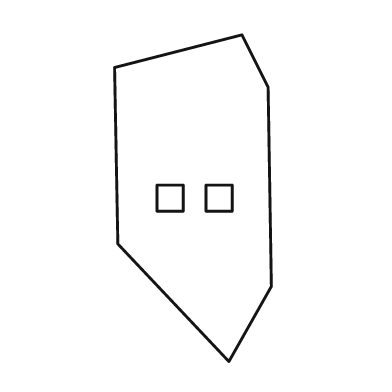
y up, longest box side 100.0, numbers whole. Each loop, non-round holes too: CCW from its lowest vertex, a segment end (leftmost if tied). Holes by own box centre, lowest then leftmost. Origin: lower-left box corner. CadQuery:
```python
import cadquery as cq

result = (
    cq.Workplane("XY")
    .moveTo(35.0, 0.0)
    .lineTo(48.0, 23.0)
    .lineTo(47.0, 84.0)
    .lineTo(39.0, 100.0)
    .lineTo(0.0, 90.0)
    .lineTo(1.0, 36.0)
    .close()
    .moveTo(13.0, 46.0)
    .lineTo(21.0, 46.0)
    .lineTo(21.0, 54.0)
    .lineTo(13.0, 54.0)
    .close()
    .moveTo(28.0, 46.0)
    .lineTo(36.0, 46.0)
    .lineTo(36.0, 54.0)
    .lineTo(28.0, 54.0)
    .close()
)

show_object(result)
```